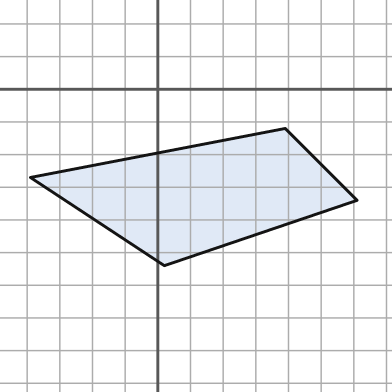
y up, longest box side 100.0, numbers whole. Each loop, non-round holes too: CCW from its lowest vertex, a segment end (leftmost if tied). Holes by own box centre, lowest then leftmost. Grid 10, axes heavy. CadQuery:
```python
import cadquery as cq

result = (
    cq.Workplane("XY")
    .moveTo(2.0, -54.0)
    .lineTo(61.0, -34.0)
    .lineTo(39.0, -12.0)
    .lineTo(-39.0, -27.0)
    .close()
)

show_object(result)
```